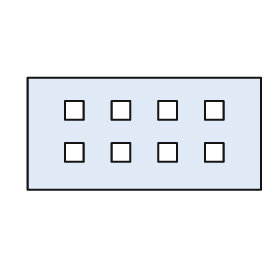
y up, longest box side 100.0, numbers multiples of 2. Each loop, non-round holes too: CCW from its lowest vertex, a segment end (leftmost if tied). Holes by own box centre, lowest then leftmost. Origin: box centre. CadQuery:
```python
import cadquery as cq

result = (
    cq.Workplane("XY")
    .moveTo(-50.0, -24.0)
    .lineTo(50.0, -24.0)
    .lineTo(50.0, 24.0)
    .lineTo(-50.0, 24.0)
    .close()
    .moveTo(-34.0, -12.0)
    .lineTo(-26.0, -12.0)
    .lineTo(-26.0, -4.0)
    .lineTo(-34.0, -4.0)
    .close()
    .moveTo(-14.0, -12.0)
    .lineTo(-6.0, -12.0)
    .lineTo(-6.0, -4.0)
    .lineTo(-14.0, -4.0)
    .close()
    .moveTo(6.0, -12.0)
    .lineTo(14.0, -12.0)
    .lineTo(14.0, -4.0)
    .lineTo(6.0, -4.0)
    .close()
    .moveTo(26.0, -12.0)
    .lineTo(34.0, -12.0)
    .lineTo(34.0, -4.0)
    .lineTo(26.0, -4.0)
    .close()
    .moveTo(-34.0, 6.0)
    .lineTo(-26.0, 6.0)
    .lineTo(-26.0, 14.0)
    .lineTo(-34.0, 14.0)
    .close()
    .moveTo(-14.0, 6.0)
    .lineTo(-6.0, 6.0)
    .lineTo(-6.0, 14.0)
    .lineTo(-14.0, 14.0)
    .close()
    .moveTo(6.0, 6.0)
    .lineTo(14.0, 6.0)
    .lineTo(14.0, 14.0)
    .lineTo(6.0, 14.0)
    .close()
    .moveTo(26.0, 6.0)
    .lineTo(34.0, 6.0)
    .lineTo(34.0, 14.0)
    .lineTo(26.0, 14.0)
    .close()
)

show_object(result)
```